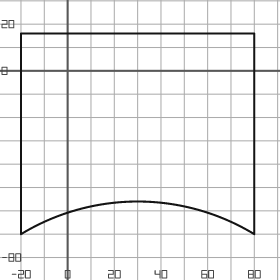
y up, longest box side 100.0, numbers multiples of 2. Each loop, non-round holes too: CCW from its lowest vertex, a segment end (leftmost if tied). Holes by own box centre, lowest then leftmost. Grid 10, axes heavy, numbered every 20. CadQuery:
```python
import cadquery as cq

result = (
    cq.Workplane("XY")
    .moveTo(-20.0, -70.0)
    .threePointArc((30.0, -56.0), (80.0, -70.0))
    .lineTo(80.0, 16.0)
    .lineTo(-20.0, 16.0)
    .close()
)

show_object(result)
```